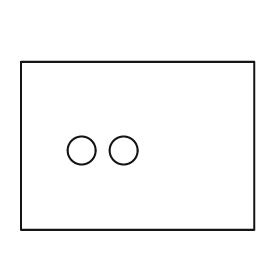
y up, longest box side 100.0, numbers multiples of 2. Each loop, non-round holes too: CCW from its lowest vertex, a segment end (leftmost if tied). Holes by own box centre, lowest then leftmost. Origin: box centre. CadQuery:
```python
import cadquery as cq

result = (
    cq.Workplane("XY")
    .moveTo(-50.0, -36.0)
    .lineTo(50.0, -36.0)
    .lineTo(50.0, 36.0)
    .lineTo(-50.0, 36.0)
    .close()
    .moveTo(-24.0, -2.0)
    .circle(6.0)
    .moveTo(-6.0, -2.0)
    .circle(6.0)
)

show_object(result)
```